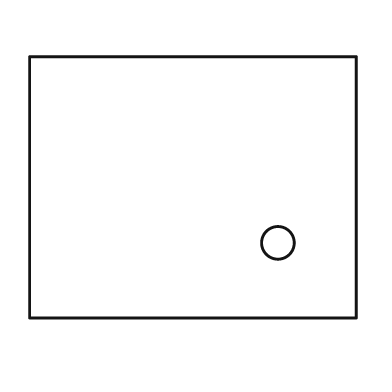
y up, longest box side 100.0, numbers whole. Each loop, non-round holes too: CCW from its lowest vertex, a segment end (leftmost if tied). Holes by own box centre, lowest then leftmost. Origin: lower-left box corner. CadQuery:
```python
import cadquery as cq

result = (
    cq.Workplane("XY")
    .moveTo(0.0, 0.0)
    .lineTo(100.0, 0.0)
    .lineTo(100.0, 80.0)
    .lineTo(0.0, 80.0)
    .close()
    .moveTo(76.0, 23.0)
    .circle(5.0)
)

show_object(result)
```